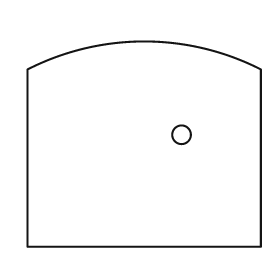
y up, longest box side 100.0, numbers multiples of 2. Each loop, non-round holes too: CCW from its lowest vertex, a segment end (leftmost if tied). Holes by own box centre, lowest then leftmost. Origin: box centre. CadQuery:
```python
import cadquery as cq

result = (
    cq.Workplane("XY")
    .moveTo(-50.0, -44.0)
    .lineTo(50.0, -44.0)
    .lineTo(50.0, 32.0)
    .threePointArc((0.0, 44.0), (-50.0, 32.0))
    .close()
    .moveTo(16.0, 4.0)
    .circle(4.0)
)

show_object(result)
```